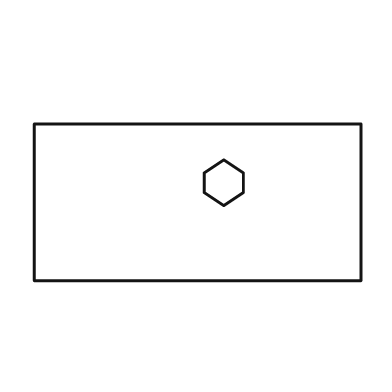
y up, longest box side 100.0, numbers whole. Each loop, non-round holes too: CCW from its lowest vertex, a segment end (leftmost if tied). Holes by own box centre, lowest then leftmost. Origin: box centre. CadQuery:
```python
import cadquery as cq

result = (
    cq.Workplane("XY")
    .moveTo(-50.0, -24.0)
    .lineTo(50.0, -24.0)
    .lineTo(50.0, 24.0)
    .lineTo(-50.0, 24.0)
    .close()
    .moveTo(8.0, -1.0)
    .lineTo(14.0, 3.0)
    .lineTo(14.0, 9.0)
    .lineTo(8.0, 13.0)
    .lineTo(2.0, 9.0)
    .lineTo(2.0, 3.0)
    .close()
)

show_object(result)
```